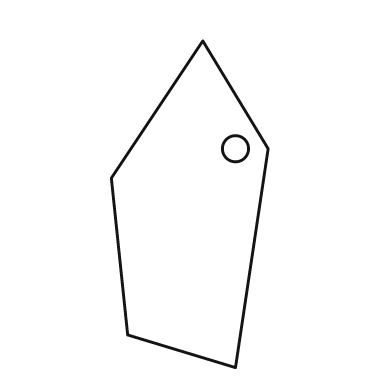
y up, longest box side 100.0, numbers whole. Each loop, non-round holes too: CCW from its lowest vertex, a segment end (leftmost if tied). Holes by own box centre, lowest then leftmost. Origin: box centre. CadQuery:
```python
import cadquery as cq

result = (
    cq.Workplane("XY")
    .moveTo(14.0, -50.0)
    .lineTo(24.0, 17.0)
    .lineTo(4.0, 50.0)
    .lineTo(-24.0, 8.0)
    .lineTo(-19.0, -40.0)
    .close()
    .moveTo(14.0, 17.0)
    .circle(4.0)
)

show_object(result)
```